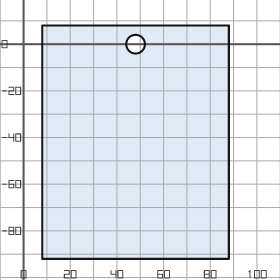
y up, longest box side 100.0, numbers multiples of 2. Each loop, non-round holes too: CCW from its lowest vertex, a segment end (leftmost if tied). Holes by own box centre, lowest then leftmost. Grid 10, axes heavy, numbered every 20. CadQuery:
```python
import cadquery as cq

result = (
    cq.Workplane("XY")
    .moveTo(8.0, -92.0)
    .lineTo(88.0, -92.0)
    .lineTo(88.0, 8.0)
    .lineTo(8.0, 8.0)
    .close()
    .moveTo(48.0, 0.0)
    .circle(4.0)
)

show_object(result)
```